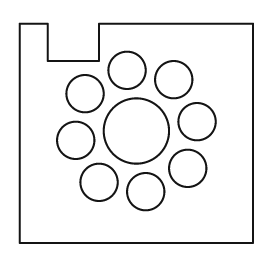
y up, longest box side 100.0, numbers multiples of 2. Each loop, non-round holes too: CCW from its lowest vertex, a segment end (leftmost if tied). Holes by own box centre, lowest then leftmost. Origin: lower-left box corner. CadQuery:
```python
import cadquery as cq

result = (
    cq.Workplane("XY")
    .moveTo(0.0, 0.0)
    .lineTo(100.0, 0.0)
    .lineTo(100.0, 94.0)
    .lineTo(34.0, 94.0)
    .lineTo(34.0, 78.0)
    .lineTo(12.0, 78.0)
    .lineTo(12.0, 94.0)
    .lineTo(0.0, 94.0)
    .close()
    .moveTo(54.0, 22.0)
    .circle(8.0)
    .moveTo(34.0, 26.0)
    .circle(8.0)
    .moveTo(72.0, 32.0)
    .circle(8.0)
    .moveTo(24.0, 44.0)
    .circle(8.0)
    .moveTo(50.0, 48.0)
    .circle(14.0)
    .moveTo(76.0, 52.0)
    .circle(8.0)
    .moveTo(28.0, 64.0)
    .circle(8.0)
    .moveTo(66.0, 70.0)
    .circle(8.0)
    .moveTo(46.0, 74.0)
    .circle(8.0)
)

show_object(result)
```